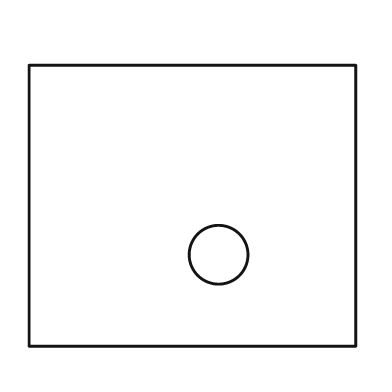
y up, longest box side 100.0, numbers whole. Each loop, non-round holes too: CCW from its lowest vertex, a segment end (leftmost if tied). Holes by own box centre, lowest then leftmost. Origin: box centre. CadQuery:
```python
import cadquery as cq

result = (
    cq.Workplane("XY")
    .moveTo(-50.0, -43.0)
    .lineTo(50.0, -43.0)
    .lineTo(50.0, 43.0)
    .lineTo(-50.0, 43.0)
    .close()
    .moveTo(8.0, -15.0)
    .circle(9.0)
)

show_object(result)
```